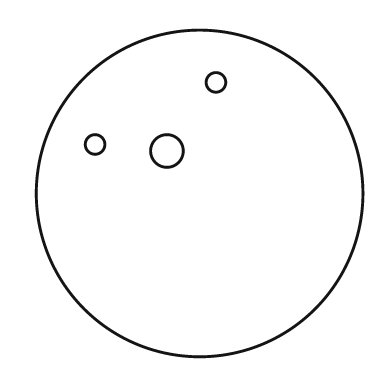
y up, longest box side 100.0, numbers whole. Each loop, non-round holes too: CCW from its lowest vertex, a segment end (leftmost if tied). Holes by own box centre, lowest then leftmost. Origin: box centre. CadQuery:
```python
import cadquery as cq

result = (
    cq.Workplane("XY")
    .moveTo(0.0, 0.0)
    .circle(50.0)
    .moveTo(-10.0, 13.0)
    .circle(5.0)
    .moveTo(-32.0, 15.0)
    .circle(3.0)
    .moveTo(5.0, 34.0)
    .circle(3.0)
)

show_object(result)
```